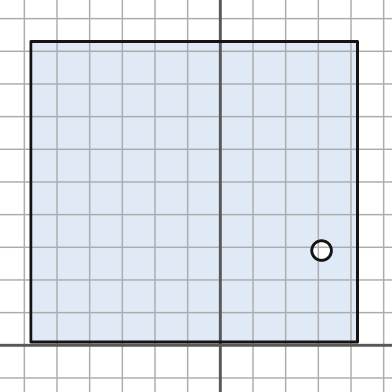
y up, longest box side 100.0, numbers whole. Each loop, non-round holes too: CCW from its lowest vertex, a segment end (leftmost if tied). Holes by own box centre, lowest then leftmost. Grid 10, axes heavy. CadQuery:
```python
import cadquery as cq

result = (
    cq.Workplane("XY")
    .moveTo(-58.0, 1.0)
    .lineTo(42.0, 1.0)
    .lineTo(42.0, 93.0)
    .lineTo(-58.0, 93.0)
    .close()
    .moveTo(31.0, 29.0)
    .circle(3.0)
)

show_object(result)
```